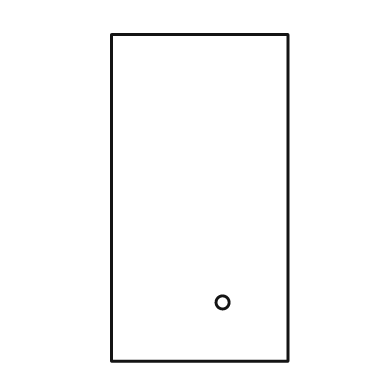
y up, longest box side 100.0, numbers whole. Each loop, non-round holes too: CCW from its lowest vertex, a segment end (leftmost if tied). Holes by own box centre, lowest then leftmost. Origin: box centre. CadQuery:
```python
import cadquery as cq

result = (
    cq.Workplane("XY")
    .moveTo(-27.0, -50.0)
    .lineTo(27.0, -50.0)
    .lineTo(27.0, 50.0)
    .lineTo(-27.0, 50.0)
    .close()
    .moveTo(7.0, -32.0)
    .circle(2.0)
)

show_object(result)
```